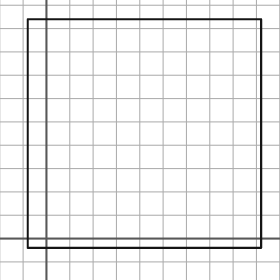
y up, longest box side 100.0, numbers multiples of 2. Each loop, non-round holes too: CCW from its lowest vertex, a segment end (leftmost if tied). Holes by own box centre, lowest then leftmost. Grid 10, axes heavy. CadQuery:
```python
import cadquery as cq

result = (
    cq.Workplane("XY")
    .moveTo(-8.0, -4.0)
    .lineTo(92.0, -4.0)
    .lineTo(92.0, 94.0)
    .lineTo(-8.0, 94.0)
    .close()
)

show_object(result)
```